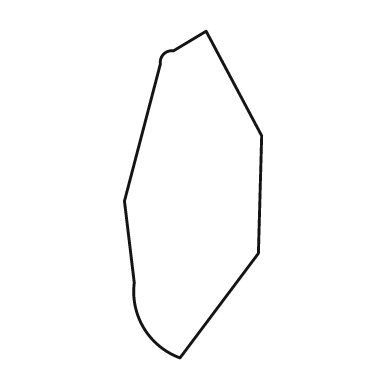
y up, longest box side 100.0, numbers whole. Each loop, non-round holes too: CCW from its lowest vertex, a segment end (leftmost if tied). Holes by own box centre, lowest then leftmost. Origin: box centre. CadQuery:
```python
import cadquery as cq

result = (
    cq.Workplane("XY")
    .moveTo(-4.0, -50.0)
    .lineTo(20.0, -18.0)
    .lineTo(21.0, 18.0)
    .lineTo(4.0, 50.0)
    .lineTo(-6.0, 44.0)
    .threePointArc((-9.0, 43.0), (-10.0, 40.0))
    .lineTo(-21.0, -2.0)
    .lineTo(-18.0, -27.0)
    .threePointArc((-15.0, -41.0), (-4.0, -50.0))
    .close()
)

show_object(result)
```